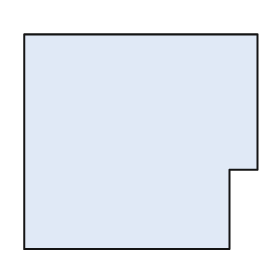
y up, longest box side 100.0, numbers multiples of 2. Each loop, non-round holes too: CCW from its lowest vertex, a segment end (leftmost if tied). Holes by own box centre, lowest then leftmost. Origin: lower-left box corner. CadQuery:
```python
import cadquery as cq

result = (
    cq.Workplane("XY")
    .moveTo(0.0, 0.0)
    .lineTo(88.0, 0.0)
    .lineTo(88.0, 34.0)
    .lineTo(100.0, 34.0)
    .lineTo(100.0, 92.0)
    .lineTo(0.0, 92.0)
    .close()
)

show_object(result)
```